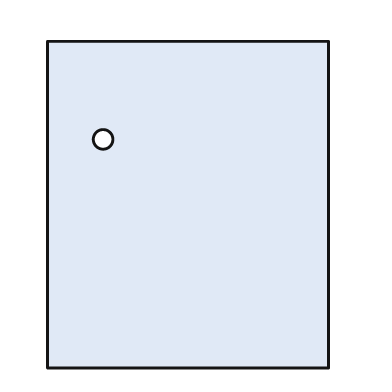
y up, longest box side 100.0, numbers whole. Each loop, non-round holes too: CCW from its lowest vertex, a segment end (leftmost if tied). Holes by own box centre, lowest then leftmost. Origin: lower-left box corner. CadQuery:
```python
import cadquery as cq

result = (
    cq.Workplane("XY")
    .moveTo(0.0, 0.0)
    .lineTo(86.0, 0.0)
    .lineTo(86.0, 100.0)
    .lineTo(0.0, 100.0)
    .close()
    .moveTo(17.0, 70.0)
    .circle(3.0)
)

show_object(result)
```